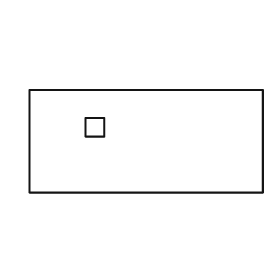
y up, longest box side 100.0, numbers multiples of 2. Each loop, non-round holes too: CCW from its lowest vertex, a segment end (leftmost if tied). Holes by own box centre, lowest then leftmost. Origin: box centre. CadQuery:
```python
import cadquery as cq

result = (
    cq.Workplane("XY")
    .moveTo(-50.0, -22.0)
    .lineTo(50.0, -22.0)
    .lineTo(50.0, 22.0)
    .lineTo(-50.0, 22.0)
    .close()
    .moveTo(-26.0, 2.0)
    .lineTo(-18.0, 2.0)
    .lineTo(-18.0, 10.0)
    .lineTo(-26.0, 10.0)
    .close()
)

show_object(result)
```